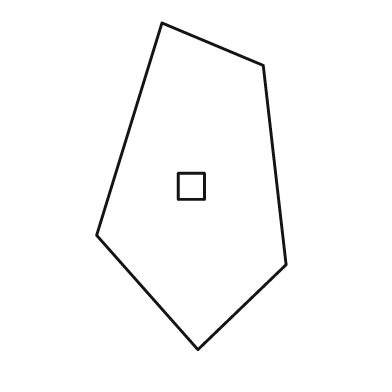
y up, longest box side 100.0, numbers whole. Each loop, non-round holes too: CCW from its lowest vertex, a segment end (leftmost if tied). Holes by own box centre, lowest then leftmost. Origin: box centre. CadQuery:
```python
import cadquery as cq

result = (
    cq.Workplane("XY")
    .moveTo(2.0, -50.0)
    .lineTo(29.0, -24.0)
    .lineTo(22.0, 37.0)
    .lineTo(-9.0, 50.0)
    .lineTo(-29.0, -15.0)
    .close()
    .moveTo(-4.0, -4.0)
    .lineTo(4.0, -4.0)
    .lineTo(4.0, 4.0)
    .lineTo(-4.0, 4.0)
    .close()
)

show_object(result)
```